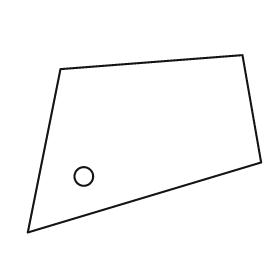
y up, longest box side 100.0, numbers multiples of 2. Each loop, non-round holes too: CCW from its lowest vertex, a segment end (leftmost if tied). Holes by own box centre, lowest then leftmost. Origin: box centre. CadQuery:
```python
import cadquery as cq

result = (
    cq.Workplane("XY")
    .moveTo(-50.0, -38.0)
    .lineTo(50.0, -8.0)
    .lineTo(42.0, 38.0)
    .lineTo(-36.0, 32.0)
    .close()
    .moveTo(-26.0, -14.0)
    .circle(4.0)
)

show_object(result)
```